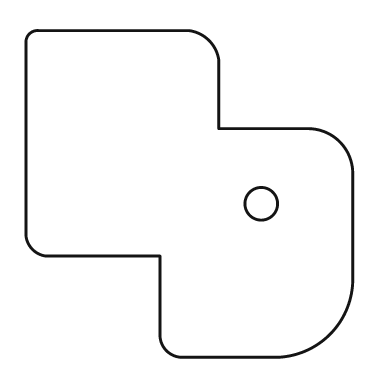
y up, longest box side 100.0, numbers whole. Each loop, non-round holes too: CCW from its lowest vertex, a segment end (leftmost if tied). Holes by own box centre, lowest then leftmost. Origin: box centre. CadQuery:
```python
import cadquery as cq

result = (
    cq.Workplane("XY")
    .moveTo(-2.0, -50.0)
    .lineTo(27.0, -50.0)
    .threePointArc((43.0, -43.0), (50.0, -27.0))
    .lineTo(50.0, 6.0)
    .threePointArc((46.0, 16.0), (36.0, 20.0))
    .lineTo(9.0, 20.0)
    .lineTo(9.0, 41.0)
    .threePointArc((6.0, 47.0), (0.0, 50.0))
    .lineTo(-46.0, 50.0)
    .threePointArc((-49.0, 49.0), (-50.0, 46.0))
    .lineTo(-50.0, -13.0)
    .threePointArc((-48.0, -17.0), (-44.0, -19.0))
    .lineTo(-9.0, -19.0)
    .lineTo(-9.0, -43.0)
    .threePointArc((-7.0, -48.0), (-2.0, -50.0))
    .close()
    .moveTo(22.0, -3.0)
    .circle(5.0)
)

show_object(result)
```